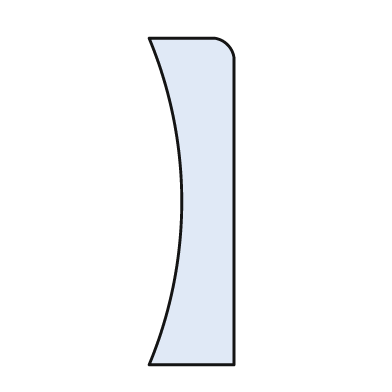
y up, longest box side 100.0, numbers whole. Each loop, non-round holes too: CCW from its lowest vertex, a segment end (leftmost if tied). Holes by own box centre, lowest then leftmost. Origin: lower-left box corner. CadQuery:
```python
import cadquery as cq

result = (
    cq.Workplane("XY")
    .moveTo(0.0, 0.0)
    .lineTo(26.0, 0.0)
    .lineTo(26.0, 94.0)
    .threePointArc((24.0, 98.0), (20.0, 100.0))
    .lineTo(0.0, 100.0)
    .threePointArc((10.0, 50.0), (0.0, 0.0))
    .close()
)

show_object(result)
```